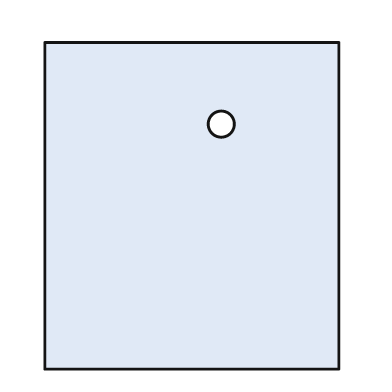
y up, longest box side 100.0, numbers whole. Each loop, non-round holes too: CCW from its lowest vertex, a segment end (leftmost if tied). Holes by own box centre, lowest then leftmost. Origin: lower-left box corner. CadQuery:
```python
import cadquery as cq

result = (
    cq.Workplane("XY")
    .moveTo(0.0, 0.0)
    .lineTo(90.0, 0.0)
    .lineTo(90.0, 100.0)
    .lineTo(0.0, 100.0)
    .close()
    .moveTo(54.0, 75.0)
    .circle(4.0)
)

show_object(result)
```